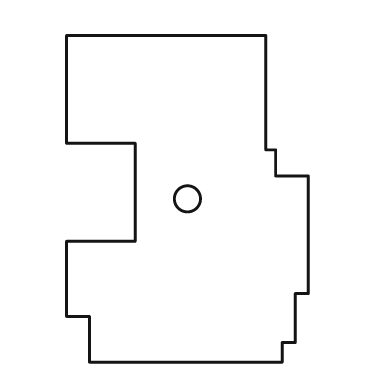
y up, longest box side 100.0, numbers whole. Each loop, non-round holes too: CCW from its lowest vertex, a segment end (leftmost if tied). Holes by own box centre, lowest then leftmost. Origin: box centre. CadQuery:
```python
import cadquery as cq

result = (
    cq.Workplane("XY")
    .moveTo(-30.0, -50.0)
    .lineTo(29.0, -50.0)
    .lineTo(29.0, -44.0)
    .lineTo(33.0, -44.0)
    .lineTo(33.0, -29.0)
    .lineTo(37.0, -29.0)
    .lineTo(37.0, 7.0)
    .lineTo(27.0, 7.0)
    .lineTo(27.0, 15.0)
    .lineTo(24.0, 15.0)
    .lineTo(24.0, 50.0)
    .lineTo(-37.0, 50.0)
    .lineTo(-37.0, 17.0)
    .lineTo(-16.0, 17.0)
    .lineTo(-16.0, -13.0)
    .lineTo(-37.0, -13.0)
    .lineTo(-37.0, -36.0)
    .lineTo(-30.0, -36.0)
    .close()
    .moveTo(0.0, 0.0)
    .circle(4.0)
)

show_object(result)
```